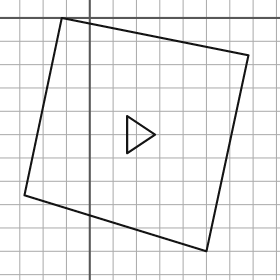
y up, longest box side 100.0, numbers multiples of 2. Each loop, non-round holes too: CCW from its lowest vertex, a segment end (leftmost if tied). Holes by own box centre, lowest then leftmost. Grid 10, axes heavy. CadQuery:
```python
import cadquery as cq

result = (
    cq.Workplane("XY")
    .moveTo(50.0, -100.0)
    .lineTo(68.0, -16.0)
    .lineTo(-12.0, 0.0)
    .lineTo(-28.0, -76.0)
    .close()
    .moveTo(16.0, -58.0)
    .lineTo(28.0, -50.0)
    .lineTo(16.0, -42.0)
    .close()
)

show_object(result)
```